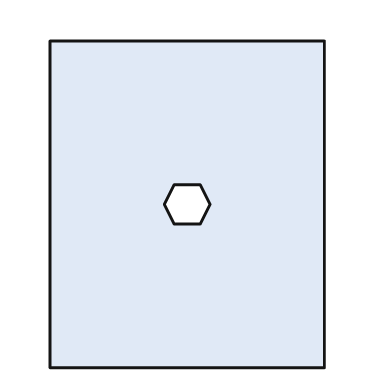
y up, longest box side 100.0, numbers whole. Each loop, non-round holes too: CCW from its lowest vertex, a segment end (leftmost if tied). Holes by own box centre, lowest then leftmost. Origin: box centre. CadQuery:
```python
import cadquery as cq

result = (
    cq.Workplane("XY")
    .moveTo(-42.0, -50.0)
    .lineTo(42.0, -50.0)
    .lineTo(42.0, 50.0)
    .lineTo(-42.0, 50.0)
    .close()
    .moveTo(-4.0, -6.0)
    .lineTo(4.0, -6.0)
    .lineTo(7.0, 0.0)
    .lineTo(4.0, 6.0)
    .lineTo(-4.0, 6.0)
    .lineTo(-7.0, 0.0)
    .close()
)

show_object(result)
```